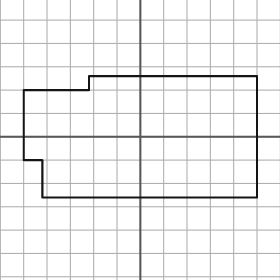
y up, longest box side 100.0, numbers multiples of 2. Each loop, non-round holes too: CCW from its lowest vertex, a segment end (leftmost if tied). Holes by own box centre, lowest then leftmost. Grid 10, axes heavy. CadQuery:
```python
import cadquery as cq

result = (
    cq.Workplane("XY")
    .moveTo(-42.0, -26.0)
    .lineTo(50.0, -26.0)
    .lineTo(50.0, 26.0)
    .lineTo(-22.0, 26.0)
    .lineTo(-22.0, 20.0)
    .lineTo(-50.0, 20.0)
    .lineTo(-50.0, -10.0)
    .lineTo(-42.0, -10.0)
    .close()
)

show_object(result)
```